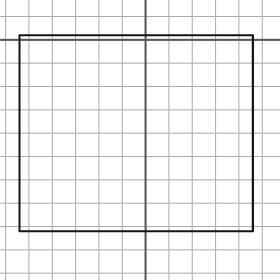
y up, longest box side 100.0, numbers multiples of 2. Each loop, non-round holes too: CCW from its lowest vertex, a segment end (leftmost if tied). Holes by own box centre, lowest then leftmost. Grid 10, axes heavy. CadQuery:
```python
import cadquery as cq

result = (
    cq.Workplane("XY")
    .moveTo(-54.0, -82.0)
    .lineTo(46.0, -82.0)
    .lineTo(46.0, 2.0)
    .lineTo(-54.0, 2.0)
    .close()
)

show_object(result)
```